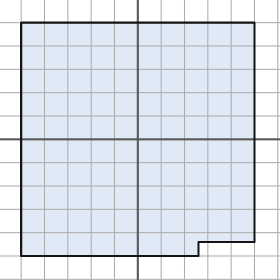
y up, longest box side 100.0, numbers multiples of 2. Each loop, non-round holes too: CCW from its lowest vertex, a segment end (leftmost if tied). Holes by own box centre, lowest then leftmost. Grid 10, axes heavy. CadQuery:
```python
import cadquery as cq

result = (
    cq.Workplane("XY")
    .moveTo(-50.0, -50.0)
    .lineTo(26.0, -50.0)
    .lineTo(26.0, -44.0)
    .lineTo(50.0, -44.0)
    .lineTo(50.0, 50.0)
    .lineTo(-50.0, 50.0)
    .close()
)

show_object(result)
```